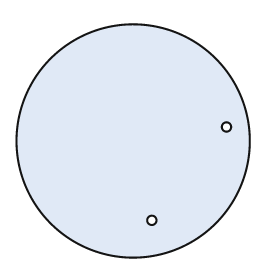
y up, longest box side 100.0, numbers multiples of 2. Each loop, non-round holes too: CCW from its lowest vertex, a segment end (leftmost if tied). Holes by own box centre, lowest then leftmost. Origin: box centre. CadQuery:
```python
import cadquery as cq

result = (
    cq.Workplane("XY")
    .moveTo(0.0, 0.0)
    .circle(50.0)
    .moveTo(8.0, -34.0)
    .circle(2.0)
    .moveTo(40.0, 6.0)
    .circle(2.0)
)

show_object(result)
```